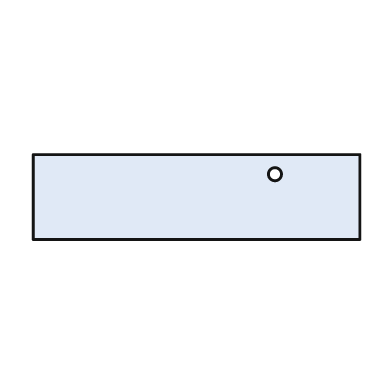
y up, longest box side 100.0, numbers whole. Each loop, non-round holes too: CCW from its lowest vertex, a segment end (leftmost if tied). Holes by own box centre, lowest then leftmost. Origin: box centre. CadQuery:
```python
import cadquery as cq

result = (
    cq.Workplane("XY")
    .moveTo(-50.0, -13.0)
    .lineTo(50.0, -13.0)
    .lineTo(50.0, 13.0)
    .lineTo(-50.0, 13.0)
    .close()
    .moveTo(24.0, 7.0)
    .circle(2.0)
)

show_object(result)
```